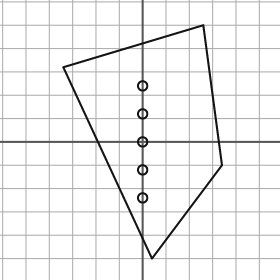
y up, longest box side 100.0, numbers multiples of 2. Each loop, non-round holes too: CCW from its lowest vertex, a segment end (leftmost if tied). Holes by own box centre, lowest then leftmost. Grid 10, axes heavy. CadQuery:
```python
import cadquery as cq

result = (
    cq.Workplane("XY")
    .moveTo(4.0, -50.0)
    .lineTo(34.0, -10.0)
    .lineTo(26.0, 50.0)
    .lineTo(-34.0, 32.0)
    .close()
    .moveTo(0.0, -24.0)
    .circle(2.0)
    .moveTo(0.0, -12.0)
    .circle(2.0)
    .moveTo(0.0, 0.0)
    .circle(2.0)
    .moveTo(0.0, 12.0)
    .circle(2.0)
    .moveTo(0.0, 24.0)
    .circle(2.0)
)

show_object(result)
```